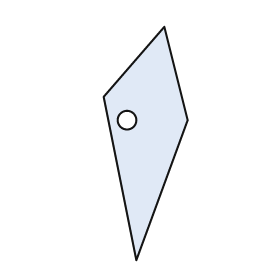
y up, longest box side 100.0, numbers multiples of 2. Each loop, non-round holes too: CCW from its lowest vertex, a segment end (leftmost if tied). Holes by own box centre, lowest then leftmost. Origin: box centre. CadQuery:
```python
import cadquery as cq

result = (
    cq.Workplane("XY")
    .moveTo(-4.0, -50.0)
    .lineTo(18.0, 10.0)
    .lineTo(8.0, 50.0)
    .lineTo(-18.0, 20.0)
    .close()
    .moveTo(-8.0, 10.0)
    .circle(4.0)
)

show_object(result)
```